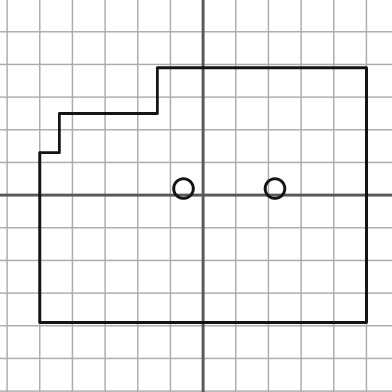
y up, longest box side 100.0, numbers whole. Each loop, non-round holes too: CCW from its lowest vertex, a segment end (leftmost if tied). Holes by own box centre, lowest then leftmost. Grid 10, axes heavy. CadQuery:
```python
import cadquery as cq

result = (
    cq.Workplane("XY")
    .moveTo(-50.0, -39.0)
    .lineTo(50.0, -39.0)
    .lineTo(50.0, 39.0)
    .lineTo(-14.0, 39.0)
    .lineTo(-14.0, 25.0)
    .lineTo(-44.0, 25.0)
    .lineTo(-44.0, 13.0)
    .lineTo(-50.0, 13.0)
    .close()
    .moveTo(-6.0, 2.0)
    .circle(3.0)
    .moveTo(22.0, 2.0)
    .circle(3.0)
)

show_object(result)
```